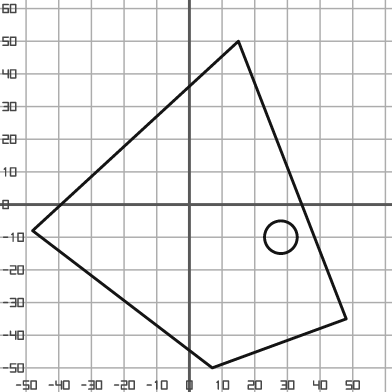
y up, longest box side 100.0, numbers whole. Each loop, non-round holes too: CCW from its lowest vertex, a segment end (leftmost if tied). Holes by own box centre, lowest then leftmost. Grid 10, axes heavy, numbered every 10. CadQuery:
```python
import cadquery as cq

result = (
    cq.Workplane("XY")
    .moveTo(7.0, -50.0)
    .lineTo(48.0, -35.0)
    .lineTo(15.0, 50.0)
    .lineTo(-48.0, -8.0)
    .close()
    .moveTo(28.0, -10.0)
    .circle(5.0)
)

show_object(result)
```